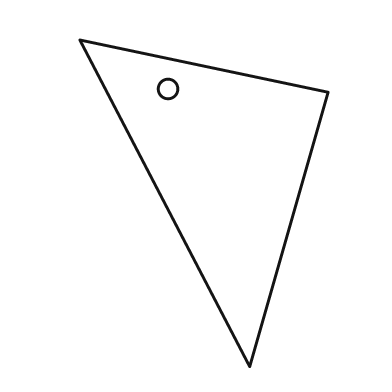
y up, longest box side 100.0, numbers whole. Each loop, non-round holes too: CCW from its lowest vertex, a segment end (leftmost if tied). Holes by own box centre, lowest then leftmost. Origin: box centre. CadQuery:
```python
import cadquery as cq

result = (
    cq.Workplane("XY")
    .moveTo(14.0, -50.0)
    .lineTo(38.0, 34.0)
    .lineTo(-38.0, 50.0)
    .close()
    .moveTo(-11.0, 35.0)
    .circle(3.0)
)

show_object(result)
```